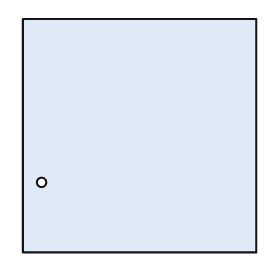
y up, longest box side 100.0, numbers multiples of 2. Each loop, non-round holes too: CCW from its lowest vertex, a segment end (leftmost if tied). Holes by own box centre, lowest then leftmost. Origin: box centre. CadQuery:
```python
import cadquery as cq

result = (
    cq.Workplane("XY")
    .moveTo(-50.0, -50.0)
    .lineTo(50.0, -50.0)
    .lineTo(50.0, 50.0)
    .lineTo(-50.0, 50.0)
    .close()
    .moveTo(-42.0, -20.0)
    .circle(2.0)
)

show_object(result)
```